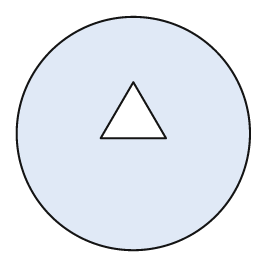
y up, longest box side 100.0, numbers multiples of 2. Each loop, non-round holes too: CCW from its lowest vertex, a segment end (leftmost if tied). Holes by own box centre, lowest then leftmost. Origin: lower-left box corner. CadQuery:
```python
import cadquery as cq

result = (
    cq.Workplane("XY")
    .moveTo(50.0, 50.0)
    .circle(50.0)
    .moveTo(36.0, 48.0)
    .lineTo(64.0, 48.0)
    .lineTo(50.0, 72.0)
    .close()
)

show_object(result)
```